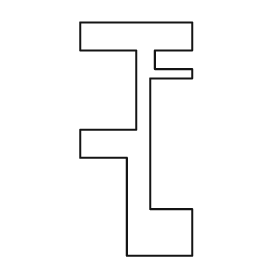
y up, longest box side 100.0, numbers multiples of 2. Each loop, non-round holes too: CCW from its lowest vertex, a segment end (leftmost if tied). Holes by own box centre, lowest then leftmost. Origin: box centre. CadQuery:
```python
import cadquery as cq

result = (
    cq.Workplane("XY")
    .moveTo(-4.0, -50.0)
    .lineTo(24.0, -50.0)
    .lineTo(24.0, -30.0)
    .lineTo(6.0, -30.0)
    .lineTo(6.0, 26.0)
    .lineTo(24.0, 26.0)
    .lineTo(24.0, 30.0)
    .lineTo(8.0, 30.0)
    .lineTo(8.0, 38.0)
    .lineTo(24.0, 38.0)
    .lineTo(24.0, 50.0)
    .lineTo(-24.0, 50.0)
    .lineTo(-24.0, 38.0)
    .lineTo(0.0, 38.0)
    .lineTo(0.0, 4.0)
    .lineTo(-24.0, 4.0)
    .lineTo(-24.0, -8.0)
    .lineTo(-4.0, -8.0)
    .close()
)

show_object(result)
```